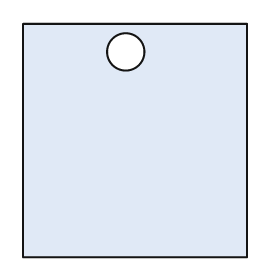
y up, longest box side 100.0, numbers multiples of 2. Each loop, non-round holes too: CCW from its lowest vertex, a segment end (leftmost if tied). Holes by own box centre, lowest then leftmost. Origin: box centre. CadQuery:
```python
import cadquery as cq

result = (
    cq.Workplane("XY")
    .moveTo(-48.0, -50.0)
    .lineTo(48.0, -50.0)
    .lineTo(48.0, 50.0)
    .lineTo(-48.0, 50.0)
    .close()
    .moveTo(-4.0, 38.0)
    .circle(8.0)
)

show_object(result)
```